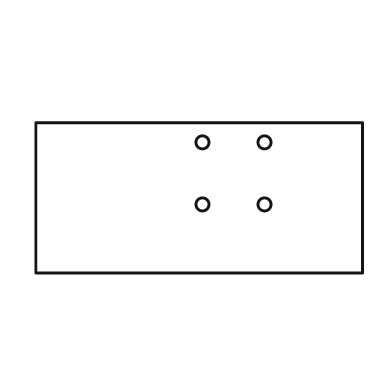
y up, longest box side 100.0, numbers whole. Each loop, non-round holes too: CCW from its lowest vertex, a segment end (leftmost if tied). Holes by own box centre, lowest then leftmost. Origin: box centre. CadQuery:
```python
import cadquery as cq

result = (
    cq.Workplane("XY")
    .moveTo(-50.0, -23.0)
    .lineTo(50.0, -23.0)
    .lineTo(50.0, 23.0)
    .lineTo(-50.0, 23.0)
    .close()
    .moveTo(1.0, -2.0)
    .circle(2.0)
    .moveTo(20.0, -2.0)
    .circle(2.0)
    .moveTo(1.0, 17.0)
    .circle(2.0)
    .moveTo(20.0, 17.0)
    .circle(2.0)
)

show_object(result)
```